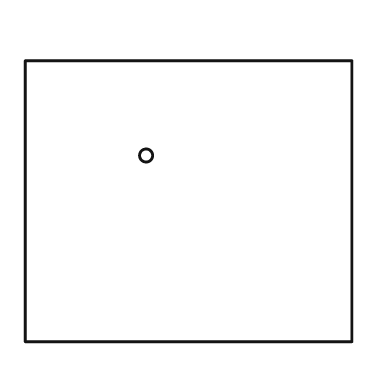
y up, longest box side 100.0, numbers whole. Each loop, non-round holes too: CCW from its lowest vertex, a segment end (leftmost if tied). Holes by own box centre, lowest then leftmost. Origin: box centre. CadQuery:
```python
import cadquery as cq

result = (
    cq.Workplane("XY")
    .moveTo(-50.0, -43.0)
    .lineTo(50.0, -43.0)
    .lineTo(50.0, 43.0)
    .lineTo(-50.0, 43.0)
    .close()
    .moveTo(-13.0, 14.0)
    .circle(2.0)
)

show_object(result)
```